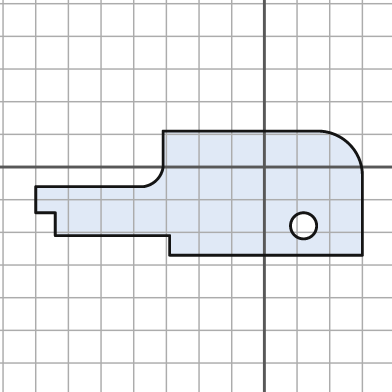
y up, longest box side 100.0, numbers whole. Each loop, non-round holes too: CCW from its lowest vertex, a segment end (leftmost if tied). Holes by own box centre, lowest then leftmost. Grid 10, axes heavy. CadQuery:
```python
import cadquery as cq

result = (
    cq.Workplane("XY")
    .moveTo(-29.0, -27.0)
    .lineTo(30.0, -27.0)
    .lineTo(30.0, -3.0)
    .threePointArc((26.0, 7.0), (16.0, 11.0))
    .lineTo(-31.0, 11.0)
    .lineTo(-31.0, 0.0)
    .threePointArc((-33.0, -4.0), (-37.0, -6.0))
    .lineTo(-70.0, -6.0)
    .lineTo(-70.0, -14.0)
    .lineTo(-64.0, -14.0)
    .lineTo(-64.0, -21.0)
    .lineTo(-29.0, -21.0)
    .close()
    .moveTo(12.0, -18.0)
    .circle(4.0)
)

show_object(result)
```